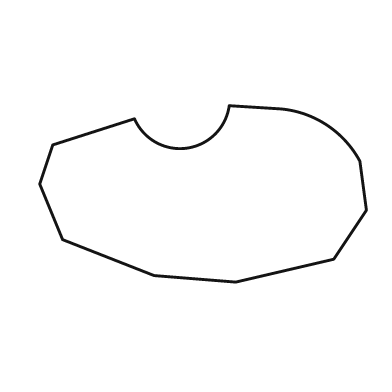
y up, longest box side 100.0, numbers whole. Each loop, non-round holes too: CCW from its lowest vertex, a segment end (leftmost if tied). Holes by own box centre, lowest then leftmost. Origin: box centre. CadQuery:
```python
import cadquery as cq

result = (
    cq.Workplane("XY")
    .moveTo(10.0, -27.0)
    .lineTo(40.0, -20.0)
    .lineTo(50.0, -5.0)
    .lineTo(48.0, 10.0)
    .threePointArc((38.0, 21.0), (24.0, 26.0))
    .lineTo(8.0, 27.0)
    .threePointArc((-5.0, 14.0), (-21.0, 23.0))
    .lineTo(-46.0, 15.0)
    .lineTo(-50.0, 3.0)
    .lineTo(-43.0, -14.0)
    .lineTo(-15.0, -25.0)
    .close()
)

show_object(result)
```